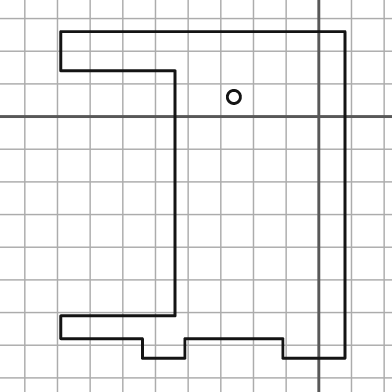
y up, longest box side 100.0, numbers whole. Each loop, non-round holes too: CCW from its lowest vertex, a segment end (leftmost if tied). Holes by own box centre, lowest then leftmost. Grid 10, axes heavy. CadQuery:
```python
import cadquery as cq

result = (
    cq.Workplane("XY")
    .moveTo(-54.0, -74.0)
    .lineTo(-41.0, -74.0)
    .lineTo(-41.0, -68.0)
    .lineTo(-11.0, -68.0)
    .lineTo(-11.0, -74.0)
    .lineTo(8.0, -74.0)
    .lineTo(8.0, 26.0)
    .lineTo(-79.0, 26.0)
    .lineTo(-79.0, 14.0)
    .lineTo(-44.0, 14.0)
    .lineTo(-44.0, -61.0)
    .lineTo(-79.0, -61.0)
    .lineTo(-79.0, -68.0)
    .lineTo(-54.0, -68.0)
    .close()
    .moveTo(-26.0, 6.0)
    .circle(2.0)
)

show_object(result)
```